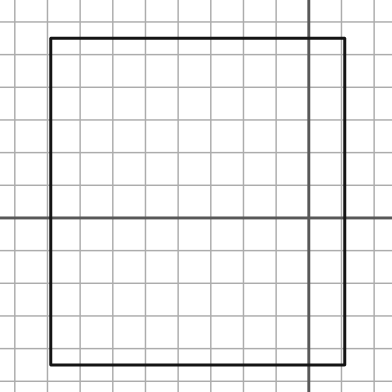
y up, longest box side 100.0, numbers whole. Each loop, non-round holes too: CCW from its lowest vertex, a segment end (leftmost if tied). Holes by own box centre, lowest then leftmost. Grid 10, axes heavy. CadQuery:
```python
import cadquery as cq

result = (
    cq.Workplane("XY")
    .moveTo(-79.0, -45.0)
    .lineTo(11.0, -45.0)
    .lineTo(11.0, 55.0)
    .lineTo(-79.0, 55.0)
    .close()
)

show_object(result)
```